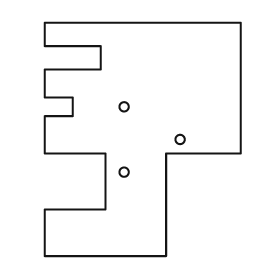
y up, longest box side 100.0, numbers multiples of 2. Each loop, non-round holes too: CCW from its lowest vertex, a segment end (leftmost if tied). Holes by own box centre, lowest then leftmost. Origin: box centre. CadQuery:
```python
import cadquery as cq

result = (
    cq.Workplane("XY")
    .moveTo(-42.0, -50.0)
    .lineTo(10.0, -50.0)
    .lineTo(10.0, -6.0)
    .lineTo(42.0, -6.0)
    .lineTo(42.0, 50.0)
    .lineTo(-42.0, 50.0)
    .lineTo(-42.0, 40.0)
    .lineTo(-18.0, 40.0)
    .lineTo(-18.0, 30.0)
    .lineTo(-42.0, 30.0)
    .lineTo(-42.0, 18.0)
    .lineTo(-30.0, 18.0)
    .lineTo(-30.0, 10.0)
    .lineTo(-42.0, 10.0)
    .lineTo(-42.0, -6.0)
    .lineTo(-16.0, -6.0)
    .lineTo(-16.0, -30.0)
    .lineTo(-42.0, -30.0)
    .close()
    .moveTo(-8.0, -14.0)
    .circle(2.0)
    .moveTo(16.0, 0.0)
    .circle(2.0)
    .moveTo(-8.0, 14.0)
    .circle(2.0)
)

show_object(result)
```